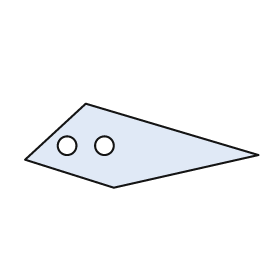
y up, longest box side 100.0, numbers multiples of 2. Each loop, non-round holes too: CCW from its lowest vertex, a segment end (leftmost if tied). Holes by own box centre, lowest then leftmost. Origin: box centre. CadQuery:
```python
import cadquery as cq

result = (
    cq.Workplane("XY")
    .moveTo(-12.0, -18.0)
    .lineTo(50.0, -4.0)
    .lineTo(-24.0, 18.0)
    .lineTo(-50.0, -6.0)
    .close()
    .moveTo(-32.0, 0.0)
    .circle(4.0)
    .moveTo(-16.0, 0.0)
    .circle(4.0)
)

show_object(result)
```